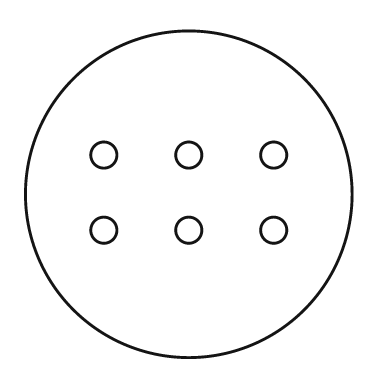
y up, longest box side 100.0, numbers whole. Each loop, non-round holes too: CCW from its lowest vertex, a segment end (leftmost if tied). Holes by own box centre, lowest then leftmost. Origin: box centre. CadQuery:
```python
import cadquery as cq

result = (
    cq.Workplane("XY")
    .moveTo(0.0, 0.0)
    .circle(50.0)
    .moveTo(-26.0, -11.0)
    .circle(4.0)
    .moveTo(0.0, -11.0)
    .circle(4.0)
    .moveTo(26.0, -11.0)
    .circle(4.0)
    .moveTo(-26.0, 12.0)
    .circle(4.0)
    .moveTo(0.0, 12.0)
    .circle(4.0)
    .moveTo(26.0, 12.0)
    .circle(4.0)
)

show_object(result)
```